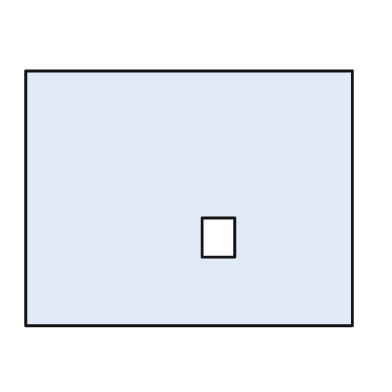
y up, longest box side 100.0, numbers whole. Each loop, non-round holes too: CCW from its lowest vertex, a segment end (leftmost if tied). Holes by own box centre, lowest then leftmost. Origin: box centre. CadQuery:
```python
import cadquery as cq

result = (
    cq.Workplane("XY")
    .moveTo(-50.0, -39.0)
    .lineTo(50.0, -39.0)
    .lineTo(50.0, 39.0)
    .lineTo(-50.0, 39.0)
    .close()
    .moveTo(4.0, -18.0)
    .lineTo(14.0, -18.0)
    .lineTo(14.0, -6.0)
    .lineTo(4.0, -6.0)
    .close()
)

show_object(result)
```